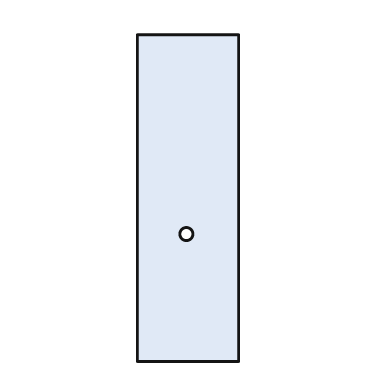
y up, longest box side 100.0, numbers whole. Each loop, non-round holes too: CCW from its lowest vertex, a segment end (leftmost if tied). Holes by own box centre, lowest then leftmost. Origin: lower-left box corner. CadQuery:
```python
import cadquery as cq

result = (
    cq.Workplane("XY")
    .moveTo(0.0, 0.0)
    .lineTo(31.0, 0.0)
    .lineTo(31.0, 100.0)
    .lineTo(0.0, 100.0)
    .close()
    .moveTo(15.0, 39.0)
    .circle(2.0)
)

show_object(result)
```